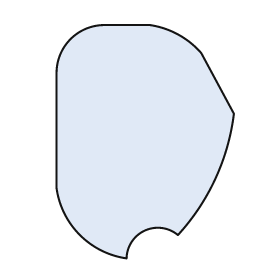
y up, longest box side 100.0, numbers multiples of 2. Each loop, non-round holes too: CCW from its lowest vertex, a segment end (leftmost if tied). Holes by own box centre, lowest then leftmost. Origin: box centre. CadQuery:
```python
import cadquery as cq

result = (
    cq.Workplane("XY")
    .moveTo(-8.0, -50.0)
    .threePointArc((0.0, -38.0), (14.0, -40.0))
    .threePointArc((30.0, -16.0), (38.0, 12.0))
    .lineTo(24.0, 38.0)
    .threePointArc((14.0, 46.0), (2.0, 50.0))
    .lineTo(-18.0, 50.0)
    .threePointArc((-32.0, 44.0), (-38.0, 30.0))
    .lineTo(-38.0, -20.0)
    .threePointArc((-28.0, -40.0), (-8.0, -50.0))
    .close()
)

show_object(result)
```